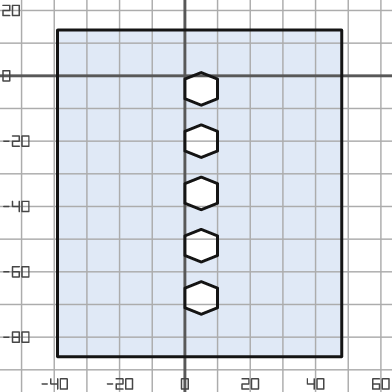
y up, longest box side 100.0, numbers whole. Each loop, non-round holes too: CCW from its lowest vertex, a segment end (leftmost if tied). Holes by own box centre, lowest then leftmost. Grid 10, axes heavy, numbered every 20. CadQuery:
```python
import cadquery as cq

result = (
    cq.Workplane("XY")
    .moveTo(-39.0, -86.0)
    .lineTo(48.0, -86.0)
    .lineTo(48.0, 14.0)
    .lineTo(-39.0, 14.0)
    .close()
    .moveTo(5.0, -73.0)
    .lineTo(10.0, -71.0)
    .lineTo(10.0, -65.0)
    .lineTo(5.0, -63.0)
    .lineTo(0.0, -65.0)
    .lineTo(0.0, -71.0)
    .close()
    .moveTo(5.0, -57.0)
    .lineTo(10.0, -55.0)
    .lineTo(10.0, -49.0)
    .lineTo(5.0, -47.0)
    .lineTo(0.0, -49.0)
    .lineTo(0.0, -55.0)
    .close()
    .moveTo(5.0, -41.0)
    .lineTo(10.0, -39.0)
    .lineTo(10.0, -33.0)
    .lineTo(5.0, -31.0)
    .lineTo(0.0, -33.0)
    .lineTo(0.0, -39.0)
    .close()
    .moveTo(5.0, -25.0)
    .lineTo(10.0, -23.0)
    .lineTo(10.0, -17.0)
    .lineTo(5.0, -15.0)
    .lineTo(0.0, -17.0)
    .lineTo(0.0, -23.0)
    .close()
    .moveTo(5.0, -9.0)
    .lineTo(10.0, -7.0)
    .lineTo(10.0, -1.0)
    .lineTo(5.0, 1.0)
    .lineTo(0.0, -1.0)
    .lineTo(0.0, -7.0)
    .close()
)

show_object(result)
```